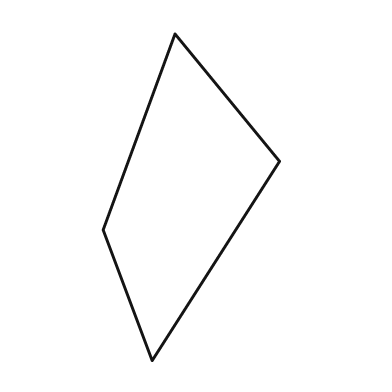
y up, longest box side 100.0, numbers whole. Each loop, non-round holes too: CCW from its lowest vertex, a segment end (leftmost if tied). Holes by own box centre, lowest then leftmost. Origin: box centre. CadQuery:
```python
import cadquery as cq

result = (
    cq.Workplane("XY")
    .moveTo(-12.0, -50.0)
    .lineTo(27.0, 11.0)
    .lineTo(-5.0, 50.0)
    .lineTo(-27.0, -10.0)
    .close()
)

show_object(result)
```